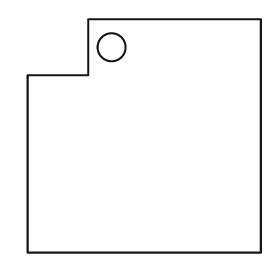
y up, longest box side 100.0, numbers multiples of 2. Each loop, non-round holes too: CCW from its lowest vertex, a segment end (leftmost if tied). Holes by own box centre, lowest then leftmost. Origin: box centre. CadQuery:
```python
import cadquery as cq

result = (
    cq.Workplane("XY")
    .moveTo(-50.0, -50.0)
    .lineTo(50.0, -50.0)
    .lineTo(50.0, 50.0)
    .lineTo(-24.0, 50.0)
    .lineTo(-24.0, 26.0)
    .lineTo(-50.0, 26.0)
    .close()
    .moveTo(-14.0, 38.0)
    .circle(6.0)
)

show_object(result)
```